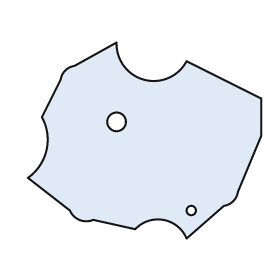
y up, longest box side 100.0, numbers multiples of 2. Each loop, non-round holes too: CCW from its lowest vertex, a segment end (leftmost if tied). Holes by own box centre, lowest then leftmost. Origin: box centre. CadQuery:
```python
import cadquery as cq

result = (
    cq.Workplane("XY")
    .moveTo(18.0, -42.0)
    .lineTo(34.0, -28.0)
    .threePointArc((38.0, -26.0), (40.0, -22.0))
    .lineTo(50.0, 2.0)
    .lineTo(50.0, 18.0)
    .lineTo(18.0, 34.0)
    .threePointArc((0.0, 26.0), (-12.0, 42.0))
    .lineTo(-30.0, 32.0)
    .threePointArc((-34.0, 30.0), (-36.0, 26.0))
    .lineTo(-44.0, 10.0)
    .threePointArc((-42.0, -4.0), (-50.0, -16.0))
    .lineTo(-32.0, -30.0)
    .threePointArc((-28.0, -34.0), (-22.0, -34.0))
    .lineTo(-4.0, -38.0)
    .threePointArc((8.0, -34.0), (18.0, -42.0))
    .close()
    .moveTo(20.0, -30.0)
    .circle(2.0)
    .moveTo(-12.0, 8.0)
    .circle(4.0)
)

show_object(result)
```